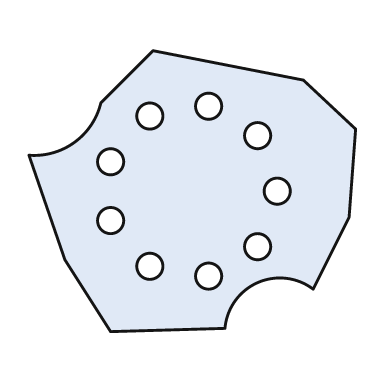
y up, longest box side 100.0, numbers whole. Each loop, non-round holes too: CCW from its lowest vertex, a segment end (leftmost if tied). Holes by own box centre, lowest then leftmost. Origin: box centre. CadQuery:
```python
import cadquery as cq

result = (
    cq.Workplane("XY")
    .moveTo(-25.0, -43.0)
    .lineTo(10.0, -42.0)
    .threePointArc((20.0, -28.0), (37.0, -30.0))
    .lineTo(48.0, -8.0)
    .lineTo(50.0, 19.0)
    .lineTo(34.0, 34.0)
    .lineTo(-12.0, 43.0)
    .lineTo(-28.0, 27.0)
    .threePointArc((-36.0, 15.0), (-50.0, 11.0))
    .lineTo(-39.0, -21.0)
    .close()
    .moveTo(5.0, -26.0)
    .circle(4.0)
    .moveTo(-13.0, -23.0)
    .circle(4.0)
    .moveTo(20.0, -17.0)
    .circle(4.0)
    .moveTo(-25.0, -9.0)
    .circle(4.0)
    .moveTo(26.0, 0.0)
    .circle(4.0)
    .moveTo(-25.0, 9.0)
    .circle(4.0)
    .moveTo(20.0, 17.0)
    .circle(4.0)
    .moveTo(-13.0, 23.0)
    .circle(4.0)
    .moveTo(5.0, 26.0)
    .circle(4.0)
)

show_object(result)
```